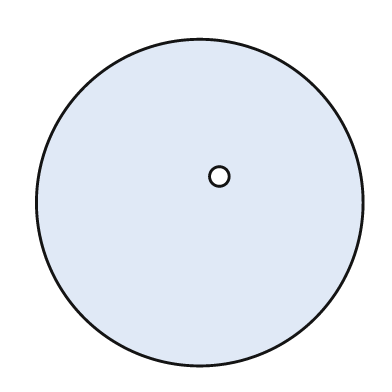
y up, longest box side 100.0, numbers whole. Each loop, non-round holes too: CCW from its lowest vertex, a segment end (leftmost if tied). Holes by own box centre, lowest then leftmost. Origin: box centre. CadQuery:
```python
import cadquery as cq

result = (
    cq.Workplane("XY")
    .moveTo(0.0, 0.0)
    .circle(50.0)
    .moveTo(6.0, 8.0)
    .circle(3.0)
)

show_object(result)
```